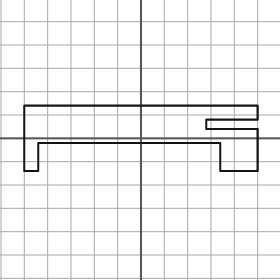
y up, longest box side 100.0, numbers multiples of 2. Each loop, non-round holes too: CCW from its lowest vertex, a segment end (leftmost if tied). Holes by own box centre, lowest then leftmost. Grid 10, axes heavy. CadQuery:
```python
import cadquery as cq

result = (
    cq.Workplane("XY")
    .moveTo(-50.0, -14.0)
    .lineTo(-44.0, -14.0)
    .lineTo(-44.0, -2.0)
    .lineTo(34.0, -2.0)
    .lineTo(34.0, -14.0)
    .lineTo(50.0, -14.0)
    .lineTo(50.0, 4.0)
    .lineTo(28.0, 4.0)
    .lineTo(28.0, 8.0)
    .lineTo(50.0, 8.0)
    .lineTo(50.0, 14.0)
    .lineTo(-50.0, 14.0)
    .close()
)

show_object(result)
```